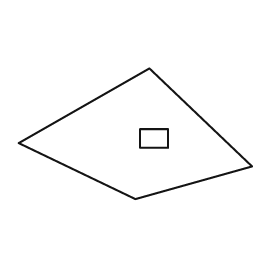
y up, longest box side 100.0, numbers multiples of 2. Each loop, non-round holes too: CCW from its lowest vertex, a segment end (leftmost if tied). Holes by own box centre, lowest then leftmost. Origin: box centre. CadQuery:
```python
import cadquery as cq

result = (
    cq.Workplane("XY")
    .moveTo(0.0, -28.0)
    .lineTo(50.0, -14.0)
    .lineTo(6.0, 28.0)
    .lineTo(-50.0, -4.0)
    .close()
    .moveTo(2.0, -6.0)
    .lineTo(14.0, -6.0)
    .lineTo(14.0, 2.0)
    .lineTo(2.0, 2.0)
    .close()
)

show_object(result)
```